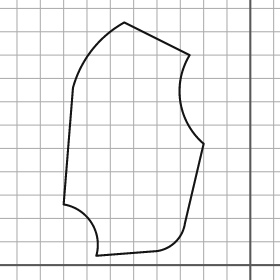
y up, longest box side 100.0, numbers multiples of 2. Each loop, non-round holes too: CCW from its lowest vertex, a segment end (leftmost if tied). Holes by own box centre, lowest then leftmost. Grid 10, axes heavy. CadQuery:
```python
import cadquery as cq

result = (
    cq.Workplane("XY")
    .moveTo(-66.0, 4.0)
    .lineTo(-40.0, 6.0)
    .threePointArc((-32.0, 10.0), (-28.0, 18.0))
    .lineTo(-20.0, 52.0)
    .threePointArc((-30.0, 70.0), (-26.0, 90.0))
    .lineTo(-54.0, 104.0)
    .threePointArc((-68.0, 92.0), (-76.0, 76.0))
    .lineTo(-80.0, 26.0)
    .threePointArc((-68.0, 18.0), (-66.0, 4.0))
    .close()
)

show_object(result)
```